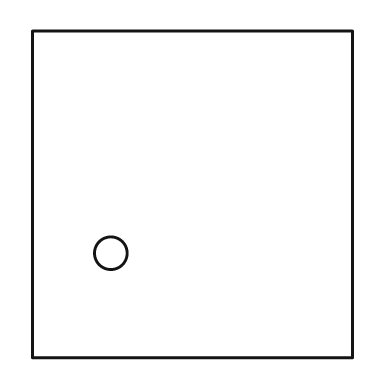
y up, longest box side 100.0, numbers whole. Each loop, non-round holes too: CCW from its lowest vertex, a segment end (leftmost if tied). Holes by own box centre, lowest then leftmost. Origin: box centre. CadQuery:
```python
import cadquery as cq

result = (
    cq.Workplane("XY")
    .moveTo(-49.0, -50.0)
    .lineTo(49.0, -50.0)
    .lineTo(49.0, 50.0)
    .lineTo(-49.0, 50.0)
    .close()
    .moveTo(-25.0, -18.0)
    .circle(5.0)
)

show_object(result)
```